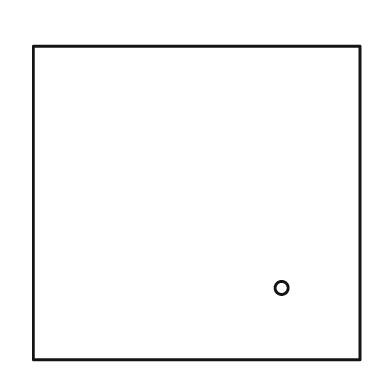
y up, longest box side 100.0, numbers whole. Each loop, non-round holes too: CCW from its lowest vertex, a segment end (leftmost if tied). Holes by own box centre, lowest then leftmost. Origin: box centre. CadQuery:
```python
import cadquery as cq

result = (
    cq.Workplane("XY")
    .moveTo(-50.0, -48.0)
    .lineTo(50.0, -48.0)
    .lineTo(50.0, 48.0)
    .lineTo(-50.0, 48.0)
    .close()
    .moveTo(26.0, -26.0)
    .circle(2.0)
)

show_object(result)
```